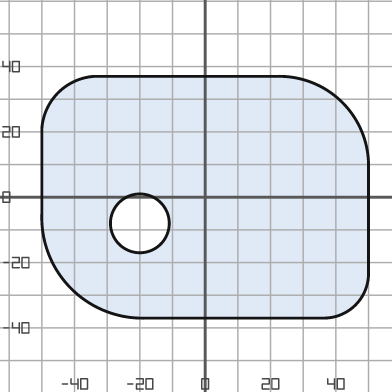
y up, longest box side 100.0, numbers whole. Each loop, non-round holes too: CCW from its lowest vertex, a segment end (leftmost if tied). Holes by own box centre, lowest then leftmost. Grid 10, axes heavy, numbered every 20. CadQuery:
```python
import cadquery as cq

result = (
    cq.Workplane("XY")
    .moveTo(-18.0, -37.0)
    .lineTo(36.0, -37.0)
    .threePointArc((46.0, -33.0), (50.0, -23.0))
    .lineTo(50.0, 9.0)
    .threePointArc((42.0, 29.0), (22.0, 37.0))
    .lineTo(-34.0, 37.0)
    .threePointArc((-45.0, 32.0), (-50.0, 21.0))
    .lineTo(-50.0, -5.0)
    .threePointArc((-41.0, -28.0), (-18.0, -37.0))
    .close()
    .moveTo(-20.0, -8.0)
    .circle(9.0)
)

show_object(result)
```